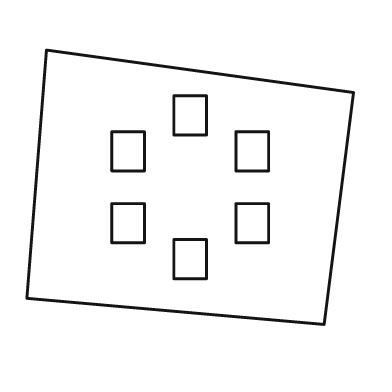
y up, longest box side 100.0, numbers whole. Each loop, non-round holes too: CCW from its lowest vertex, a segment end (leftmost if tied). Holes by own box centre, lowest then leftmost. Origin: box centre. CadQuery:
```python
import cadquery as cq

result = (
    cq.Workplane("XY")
    .moveTo(41.0, -42.0)
    .lineTo(50.0, 29.0)
    .lineTo(-44.0, 42.0)
    .lineTo(-50.0, -34.0)
    .close()
    .moveTo(-5.0, -28.0)
    .lineTo(5.0, -28.0)
    .lineTo(5.0, -16.0)
    .lineTo(-5.0, -16.0)
    .close()
    .moveTo(-24.0, -17.0)
    .lineTo(-14.0, -17.0)
    .lineTo(-14.0, -5.0)
    .lineTo(-24.0, -5.0)
    .close()
    .moveTo(14.0, -17.0)
    .lineTo(24.0, -17.0)
    .lineTo(24.0, -5.0)
    .lineTo(14.0, -5.0)
    .close()
    .moveTo(-24.0, 5.0)
    .lineTo(-14.0, 5.0)
    .lineTo(-14.0, 17.0)
    .lineTo(-24.0, 17.0)
    .close()
    .moveTo(14.0, 5.0)
    .lineTo(24.0, 5.0)
    .lineTo(24.0, 17.0)
    .lineTo(14.0, 17.0)
    .close()
    .moveTo(-5.0, 16.0)
    .lineTo(5.0, 16.0)
    .lineTo(5.0, 28.0)
    .lineTo(-5.0, 28.0)
    .close()
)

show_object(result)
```